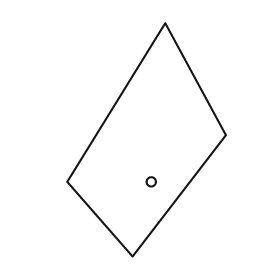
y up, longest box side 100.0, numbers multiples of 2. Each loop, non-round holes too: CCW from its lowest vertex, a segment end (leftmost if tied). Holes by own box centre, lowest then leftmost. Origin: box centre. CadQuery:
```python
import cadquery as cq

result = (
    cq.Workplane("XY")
    .moveTo(-6.0, -50.0)
    .lineTo(34.0, 2.0)
    .lineTo(8.0, 50.0)
    .lineTo(-34.0, -18.0)
    .close()
    .moveTo(2.0, -18.0)
    .circle(2.0)
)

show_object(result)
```